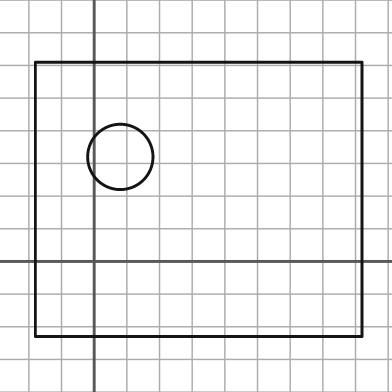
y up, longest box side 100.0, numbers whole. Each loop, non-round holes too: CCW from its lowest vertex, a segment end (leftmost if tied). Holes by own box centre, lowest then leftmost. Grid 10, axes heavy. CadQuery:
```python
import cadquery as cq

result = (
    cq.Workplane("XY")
    .moveTo(-18.0, -23.0)
    .lineTo(82.0, -23.0)
    .lineTo(82.0, 61.0)
    .lineTo(-18.0, 61.0)
    .close()
    .moveTo(8.0, 32.0)
    .circle(10.0)
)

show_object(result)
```